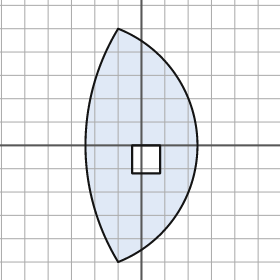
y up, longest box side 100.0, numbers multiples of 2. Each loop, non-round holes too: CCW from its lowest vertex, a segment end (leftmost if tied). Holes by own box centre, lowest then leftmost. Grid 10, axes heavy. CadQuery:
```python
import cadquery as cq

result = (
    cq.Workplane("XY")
    .moveTo(-10.0, -50.0)
    .threePointArc((24.0, 0.0), (-10.0, 50.0))
    .threePointArc((-24.0, 0.0), (-10.0, -50.0))
    .close()
    .moveTo(-4.0, -12.0)
    .lineTo(8.0, -12.0)
    .lineTo(8.0, 0.0)
    .lineTo(-4.0, 0.0)
    .close()
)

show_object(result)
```